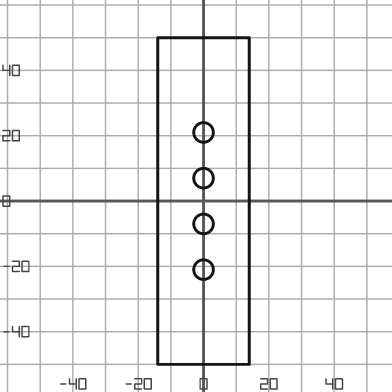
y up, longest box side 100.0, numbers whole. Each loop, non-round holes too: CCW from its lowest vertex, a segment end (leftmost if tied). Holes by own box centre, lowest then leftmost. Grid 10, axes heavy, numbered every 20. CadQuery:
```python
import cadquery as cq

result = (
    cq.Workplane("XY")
    .moveTo(-14.0, -50.0)
    .lineTo(14.0, -50.0)
    .lineTo(14.0, 50.0)
    .lineTo(-14.0, 50.0)
    .close()
    .moveTo(0.0, -21.0)
    .circle(3.0)
    .moveTo(0.0, -7.0)
    .circle(3.0)
    .moveTo(0.0, 7.0)
    .circle(3.0)
    .moveTo(0.0, 21.0)
    .circle(3.0)
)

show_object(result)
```